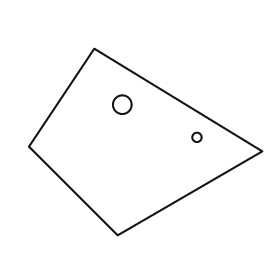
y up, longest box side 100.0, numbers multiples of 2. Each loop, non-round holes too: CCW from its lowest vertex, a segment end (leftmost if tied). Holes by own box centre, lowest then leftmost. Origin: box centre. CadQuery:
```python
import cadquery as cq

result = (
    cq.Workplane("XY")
    .moveTo(-12.0, -40.0)
    .lineTo(50.0, -4.0)
    .lineTo(-22.0, 40.0)
    .lineTo(-50.0, -2.0)
    .close()
    .moveTo(22.0, 2.0)
    .circle(2.0)
    .moveTo(-10.0, 16.0)
    .circle(4.0)
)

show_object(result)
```